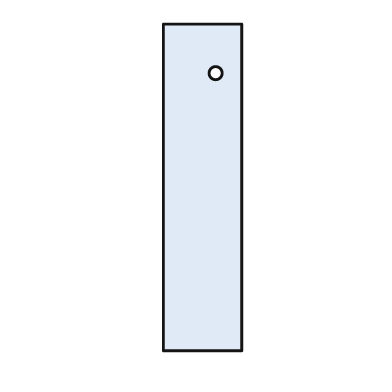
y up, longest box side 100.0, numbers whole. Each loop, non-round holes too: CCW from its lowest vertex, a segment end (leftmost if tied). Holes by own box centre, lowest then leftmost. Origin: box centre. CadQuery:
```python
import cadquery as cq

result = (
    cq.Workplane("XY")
    .moveTo(-12.0, -50.0)
    .lineTo(12.0, -50.0)
    .lineTo(12.0, 50.0)
    .lineTo(-12.0, 50.0)
    .close()
    .moveTo(4.0, 35.0)
    .circle(2.0)
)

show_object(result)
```